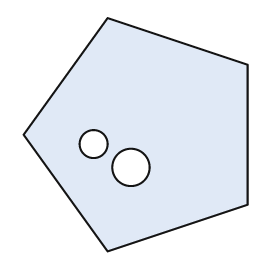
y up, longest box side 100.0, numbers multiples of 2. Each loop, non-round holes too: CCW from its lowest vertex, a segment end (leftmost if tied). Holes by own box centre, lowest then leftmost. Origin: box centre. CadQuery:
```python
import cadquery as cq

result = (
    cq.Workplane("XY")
    .moveTo(-12.0, -50.0)
    .lineTo(48.0, -30.0)
    .lineTo(48.0, 30.0)
    .lineTo(-12.0, 50.0)
    .lineTo(-48.0, 0.0)
    .close()
    .moveTo(-2.0, -14.0)
    .circle(8.0)
    .moveTo(-18.0, -4.0)
    .circle(6.0)
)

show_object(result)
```